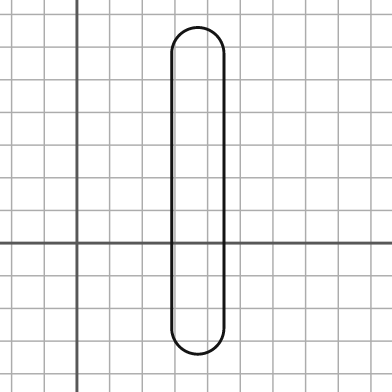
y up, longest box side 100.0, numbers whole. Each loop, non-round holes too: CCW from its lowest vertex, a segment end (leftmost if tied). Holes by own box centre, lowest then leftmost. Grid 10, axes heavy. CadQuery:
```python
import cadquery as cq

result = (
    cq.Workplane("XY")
    .moveTo(29.0, -26.0)
    .threePointArc((37.0, -34.0), (45.0, -26.0))
    .lineTo(45.0, 58.0)
    .threePointArc((37.0, 66.0), (29.0, 58.0))
    .close()
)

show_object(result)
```